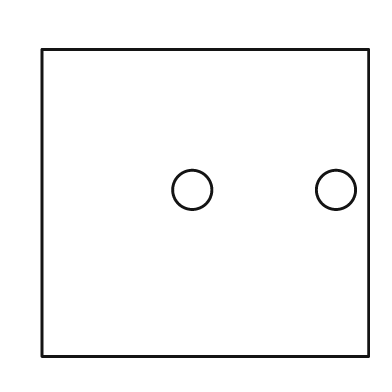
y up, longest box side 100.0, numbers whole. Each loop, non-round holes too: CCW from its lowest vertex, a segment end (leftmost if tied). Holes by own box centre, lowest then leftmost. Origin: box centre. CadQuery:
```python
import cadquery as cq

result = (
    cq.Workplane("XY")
    .moveTo(-50.0, -47.0)
    .lineTo(50.0, -47.0)
    .lineTo(50.0, 47.0)
    .lineTo(-50.0, 47.0)
    .close()
    .moveTo(-4.0, 4.0)
    .circle(6.0)
    .moveTo(40.0, 4.0)
    .circle(6.0)
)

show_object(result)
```